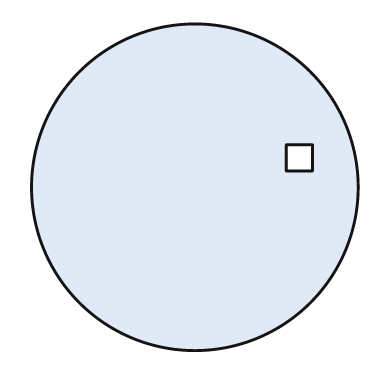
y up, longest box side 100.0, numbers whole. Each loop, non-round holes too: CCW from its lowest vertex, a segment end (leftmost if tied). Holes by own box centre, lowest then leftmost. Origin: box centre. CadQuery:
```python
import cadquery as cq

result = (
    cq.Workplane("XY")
    .moveTo(0.0, 0.0)
    .circle(50.0)
    .moveTo(28.0, 5.0)
    .lineTo(36.0, 5.0)
    .lineTo(36.0, 13.0)
    .lineTo(28.0, 13.0)
    .close()
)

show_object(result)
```